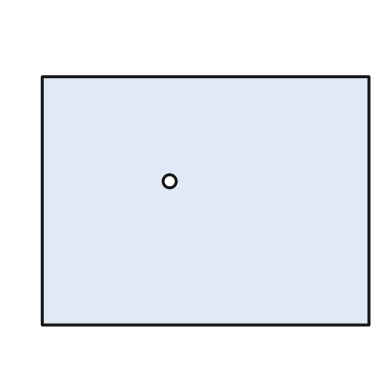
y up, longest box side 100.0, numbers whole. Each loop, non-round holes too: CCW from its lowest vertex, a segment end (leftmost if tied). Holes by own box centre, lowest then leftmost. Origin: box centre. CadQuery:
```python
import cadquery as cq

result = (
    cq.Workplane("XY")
    .moveTo(-50.0, -38.0)
    .lineTo(50.0, -38.0)
    .lineTo(50.0, 38.0)
    .lineTo(-50.0, 38.0)
    .close()
    .moveTo(-11.0, 6.0)
    .circle(2.0)
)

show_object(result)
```